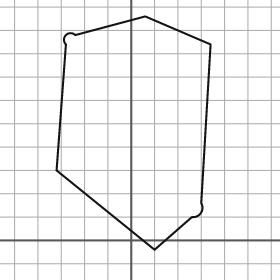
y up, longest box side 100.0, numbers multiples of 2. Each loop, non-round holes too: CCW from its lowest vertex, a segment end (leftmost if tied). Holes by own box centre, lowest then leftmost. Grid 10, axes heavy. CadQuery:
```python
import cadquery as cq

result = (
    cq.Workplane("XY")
    .moveTo(10.0, -4.0)
    .lineTo(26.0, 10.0)
    .threePointArc((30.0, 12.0), (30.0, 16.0))
    .lineTo(34.0, 84.0)
    .lineTo(6.0, 96.0)
    .lineTo(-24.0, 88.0)
    .threePointArc((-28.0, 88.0), (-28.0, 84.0))
    .lineTo(-32.0, 30.0)
    .close()
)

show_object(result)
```